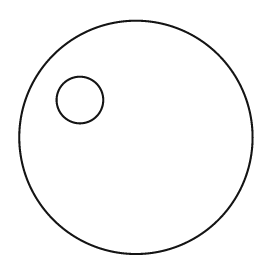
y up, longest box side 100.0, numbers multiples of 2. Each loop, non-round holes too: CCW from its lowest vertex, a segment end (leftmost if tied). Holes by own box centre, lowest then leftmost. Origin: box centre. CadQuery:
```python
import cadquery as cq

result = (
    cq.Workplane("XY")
    .moveTo(0.0, 0.0)
    .circle(50.0)
    .moveTo(-24.0, 16.0)
    .circle(10.0)
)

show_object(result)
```